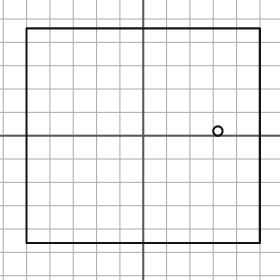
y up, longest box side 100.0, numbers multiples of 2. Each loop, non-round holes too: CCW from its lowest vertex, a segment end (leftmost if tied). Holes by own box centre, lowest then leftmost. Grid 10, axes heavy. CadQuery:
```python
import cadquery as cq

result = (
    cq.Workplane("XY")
    .moveTo(-50.0, -46.0)
    .lineTo(50.0, -46.0)
    .lineTo(50.0, 46.0)
    .lineTo(-50.0, 46.0)
    .close()
    .moveTo(32.0, 2.0)
    .circle(2.0)
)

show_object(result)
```